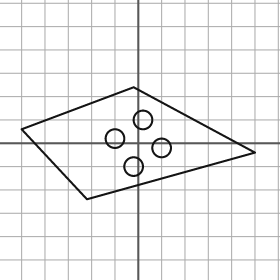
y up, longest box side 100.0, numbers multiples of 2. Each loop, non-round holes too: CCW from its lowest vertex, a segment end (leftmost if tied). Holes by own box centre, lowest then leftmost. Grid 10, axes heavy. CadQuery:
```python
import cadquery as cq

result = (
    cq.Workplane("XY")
    .moveTo(-22.0, -24.0)
    .lineTo(50.0, -4.0)
    .lineTo(-2.0, 24.0)
    .lineTo(-50.0, 6.0)
    .close()
    .moveTo(-2.0, -10.0)
    .circle(4.0)
    .moveTo(10.0, -2.0)
    .circle(4.0)
    .moveTo(-10.0, 2.0)
    .circle(4.0)
    .moveTo(2.0, 10.0)
    .circle(4.0)
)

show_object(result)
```